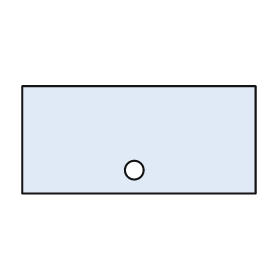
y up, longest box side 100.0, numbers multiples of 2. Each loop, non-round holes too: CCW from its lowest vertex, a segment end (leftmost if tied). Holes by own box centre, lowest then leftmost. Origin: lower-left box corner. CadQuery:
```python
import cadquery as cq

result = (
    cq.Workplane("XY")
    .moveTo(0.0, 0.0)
    .lineTo(100.0, 0.0)
    .lineTo(100.0, 46.0)
    .lineTo(0.0, 46.0)
    .close()
    .moveTo(48.0, 10.0)
    .circle(4.0)
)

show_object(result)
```